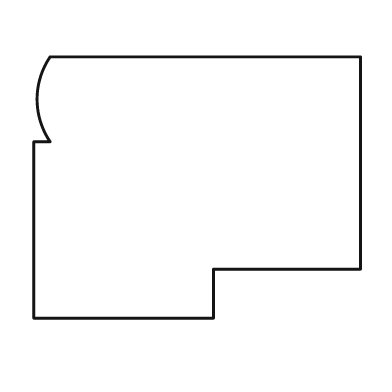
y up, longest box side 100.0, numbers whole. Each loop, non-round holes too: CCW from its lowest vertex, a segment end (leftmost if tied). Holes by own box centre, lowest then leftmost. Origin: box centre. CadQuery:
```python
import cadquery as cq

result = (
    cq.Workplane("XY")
    .moveTo(-50.0, -40.0)
    .lineTo(5.0, -40.0)
    .lineTo(5.0, -25.0)
    .lineTo(50.0, -25.0)
    .lineTo(50.0, 40.0)
    .lineTo(-45.0, 40.0)
    .threePointArc((-49.0, 27.0), (-45.0, 14.0))
    .lineTo(-50.0, 14.0)
    .close()
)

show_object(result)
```